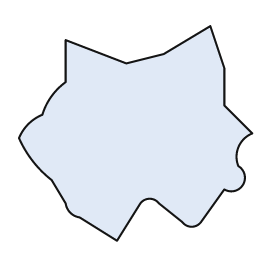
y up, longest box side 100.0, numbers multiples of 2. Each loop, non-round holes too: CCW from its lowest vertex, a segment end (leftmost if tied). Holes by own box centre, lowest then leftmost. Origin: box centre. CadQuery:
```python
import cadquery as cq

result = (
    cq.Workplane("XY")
    .moveTo(-8.0, -46.0)
    .lineTo(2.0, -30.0)
    .threePointArc((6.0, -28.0), (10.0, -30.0))
    .lineTo(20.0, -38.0)
    .threePointArc((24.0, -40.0), (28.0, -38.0))
    .lineTo(38.0, -24.0)
    .threePointArc((46.0, -22.0), (44.0, -14.0))
    .threePointArc((44.0, -6.0), (50.0, 0.0))
    .lineTo(38.0, 12.0)
    .lineTo(38.0, 28.0)
    .lineTo(32.0, 46.0)
    .lineTo(12.0, 34.0)
    .lineTo(-4.0, 30.0)
    .lineTo(-30.0, 40.0)
    .lineTo(-30.0, 22.0)
    .threePointArc((-36.0, 16.0), (-40.0, 8.0))
    .threePointArc((-46.0, 4.0), (-50.0, -2.0))
    .threePointArc((-44.0, -12.0), (-36.0, -20.0))
    .lineTo(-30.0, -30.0)
    .threePointArc((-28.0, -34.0), (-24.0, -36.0))
    .close()
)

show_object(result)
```